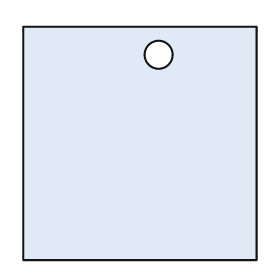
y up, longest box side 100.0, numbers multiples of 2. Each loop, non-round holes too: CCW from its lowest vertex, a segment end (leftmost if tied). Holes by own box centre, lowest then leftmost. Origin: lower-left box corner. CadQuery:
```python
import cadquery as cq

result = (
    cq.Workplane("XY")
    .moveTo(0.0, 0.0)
    .lineTo(100.0, 0.0)
    .lineTo(100.0, 100.0)
    .lineTo(0.0, 100.0)
    .close()
    .moveTo(58.0, 88.0)
    .circle(6.0)
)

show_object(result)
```